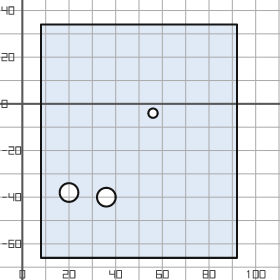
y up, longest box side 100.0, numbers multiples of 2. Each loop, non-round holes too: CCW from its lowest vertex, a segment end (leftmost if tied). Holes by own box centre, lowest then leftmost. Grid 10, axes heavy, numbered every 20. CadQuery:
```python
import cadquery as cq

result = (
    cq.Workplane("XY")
    .moveTo(8.0, -66.0)
    .lineTo(92.0, -66.0)
    .lineTo(92.0, 34.0)
    .lineTo(8.0, 34.0)
    .close()
    .moveTo(36.0, -40.0)
    .circle(4.0)
    .moveTo(20.0, -38.0)
    .circle(4.0)
    .moveTo(56.0, -4.0)
    .circle(2.0)
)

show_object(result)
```